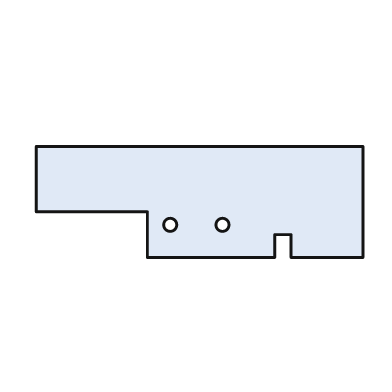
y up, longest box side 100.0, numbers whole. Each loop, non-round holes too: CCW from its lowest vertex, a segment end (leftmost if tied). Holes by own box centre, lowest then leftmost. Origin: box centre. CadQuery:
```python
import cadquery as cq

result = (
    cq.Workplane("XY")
    .moveTo(-16.0, -17.0)
    .lineTo(23.0, -17.0)
    .lineTo(23.0, -10.0)
    .lineTo(28.0, -10.0)
    .lineTo(28.0, -17.0)
    .lineTo(50.0, -17.0)
    .lineTo(50.0, 17.0)
    .lineTo(-50.0, 17.0)
    .lineTo(-50.0, -3.0)
    .lineTo(-16.0, -3.0)
    .close()
    .moveTo(-9.0, -7.0)
    .circle(2.0)
    .moveTo(7.0, -7.0)
    .circle(2.0)
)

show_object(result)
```